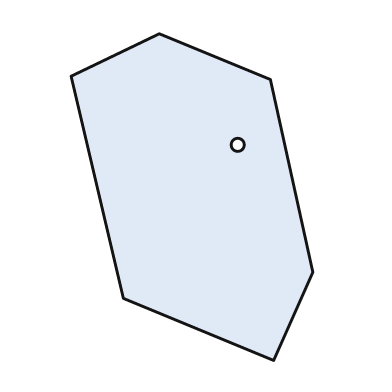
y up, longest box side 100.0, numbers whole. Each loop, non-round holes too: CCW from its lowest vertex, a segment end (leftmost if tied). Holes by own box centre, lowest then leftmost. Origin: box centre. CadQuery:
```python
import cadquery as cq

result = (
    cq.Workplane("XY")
    .moveTo(25.0, -50.0)
    .lineTo(37.0, -23.0)
    .lineTo(24.0, 36.0)
    .lineTo(-10.0, 50.0)
    .lineTo(-37.0, 37.0)
    .lineTo(-21.0, -31.0)
    .close()
    .moveTo(14.0, 16.0)
    .circle(2.0)
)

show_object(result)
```